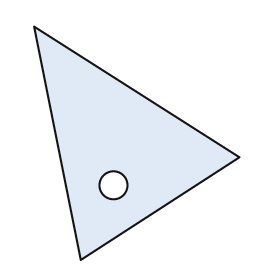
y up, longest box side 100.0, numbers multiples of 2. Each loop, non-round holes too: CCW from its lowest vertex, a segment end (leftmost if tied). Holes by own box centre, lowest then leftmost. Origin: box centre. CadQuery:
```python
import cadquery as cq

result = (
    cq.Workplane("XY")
    .moveTo(-24.0, -50.0)
    .lineTo(44.0, -6.0)
    .lineTo(-44.0, 50.0)
    .close()
    .moveTo(-10.0, -18.0)
    .circle(6.0)
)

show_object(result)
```